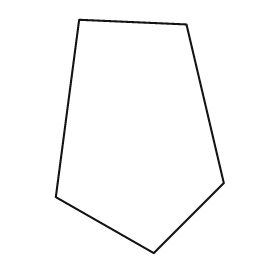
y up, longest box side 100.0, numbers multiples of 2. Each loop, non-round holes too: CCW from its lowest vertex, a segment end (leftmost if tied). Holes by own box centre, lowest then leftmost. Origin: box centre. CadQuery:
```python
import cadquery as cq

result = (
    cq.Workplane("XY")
    .moveTo(6.0, -50.0)
    .lineTo(36.0, -20.0)
    .lineTo(20.0, 48.0)
    .lineTo(-26.0, 50.0)
    .lineTo(-36.0, -26.0)
    .close()
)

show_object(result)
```